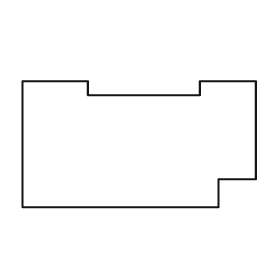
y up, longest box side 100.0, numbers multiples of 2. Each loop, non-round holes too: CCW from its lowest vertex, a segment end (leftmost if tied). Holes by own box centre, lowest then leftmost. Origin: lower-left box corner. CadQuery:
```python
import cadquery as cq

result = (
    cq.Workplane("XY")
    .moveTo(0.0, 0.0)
    .lineTo(84.0, 0.0)
    .lineTo(84.0, 12.0)
    .lineTo(100.0, 12.0)
    .lineTo(100.0, 54.0)
    .lineTo(76.0, 54.0)
    .lineTo(76.0, 48.0)
    .lineTo(28.0, 48.0)
    .lineTo(28.0, 54.0)
    .lineTo(0.0, 54.0)
    .close()
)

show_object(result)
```